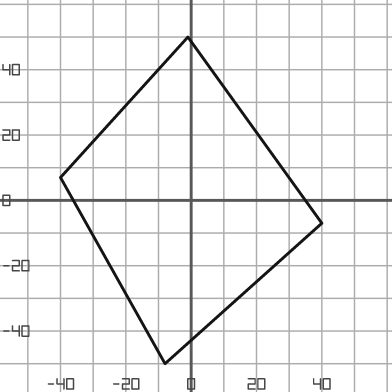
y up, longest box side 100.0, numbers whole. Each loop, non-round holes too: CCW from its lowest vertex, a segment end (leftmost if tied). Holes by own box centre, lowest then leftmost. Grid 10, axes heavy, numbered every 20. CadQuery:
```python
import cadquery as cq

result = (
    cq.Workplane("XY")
    .moveTo(-8.0, -50.0)
    .lineTo(40.0, -7.0)
    .lineTo(-1.0, 50.0)
    .lineTo(-40.0, 7.0)
    .close()
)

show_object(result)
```